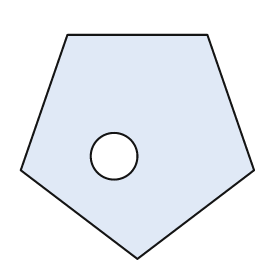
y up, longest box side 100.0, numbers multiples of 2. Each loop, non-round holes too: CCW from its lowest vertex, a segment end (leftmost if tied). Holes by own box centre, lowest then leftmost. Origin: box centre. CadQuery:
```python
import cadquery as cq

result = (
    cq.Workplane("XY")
    .moveTo(0.0, -48.0)
    .lineTo(50.0, -10.0)
    .lineTo(30.0, 48.0)
    .lineTo(-30.0, 48.0)
    .lineTo(-50.0, -10.0)
    .close()
    .moveTo(-10.0, -4.0)
    .circle(10.0)
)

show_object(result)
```